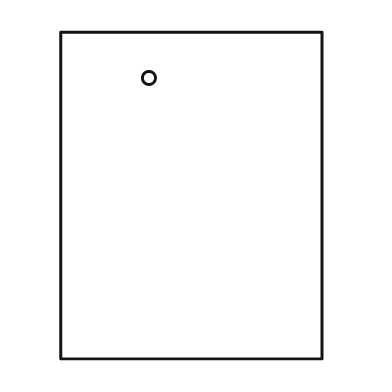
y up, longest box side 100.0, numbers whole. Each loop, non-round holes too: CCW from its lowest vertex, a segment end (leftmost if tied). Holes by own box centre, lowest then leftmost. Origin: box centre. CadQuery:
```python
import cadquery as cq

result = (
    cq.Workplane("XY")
    .moveTo(-40.0, -50.0)
    .lineTo(40.0, -50.0)
    .lineTo(40.0, 50.0)
    .lineTo(-40.0, 50.0)
    .close()
    .moveTo(-13.0, 36.0)
    .circle(2.0)
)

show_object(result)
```